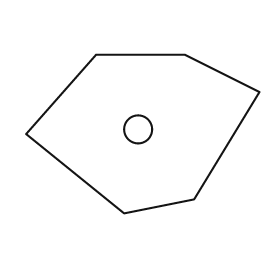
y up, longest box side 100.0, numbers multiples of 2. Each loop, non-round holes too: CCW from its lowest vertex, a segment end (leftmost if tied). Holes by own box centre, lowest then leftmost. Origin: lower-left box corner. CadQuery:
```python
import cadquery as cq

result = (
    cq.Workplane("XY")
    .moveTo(42.0, 0.0)
    .lineTo(72.0, 6.0)
    .lineTo(100.0, 52.0)
    .lineTo(68.0, 68.0)
    .lineTo(30.0, 68.0)
    .lineTo(0.0, 34.0)
    .close()
    .moveTo(48.0, 36.0)
    .circle(6.0)
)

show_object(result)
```